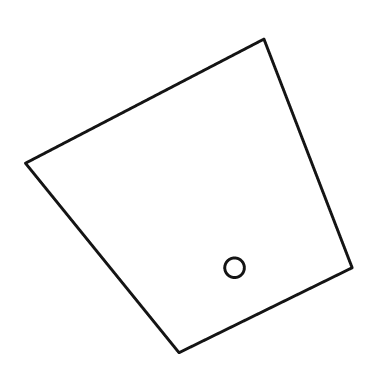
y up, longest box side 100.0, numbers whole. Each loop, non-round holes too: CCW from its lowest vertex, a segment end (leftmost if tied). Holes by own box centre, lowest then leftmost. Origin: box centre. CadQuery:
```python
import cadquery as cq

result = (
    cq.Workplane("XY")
    .moveTo(-3.0, -48.0)
    .lineTo(50.0, -22.0)
    .lineTo(23.0, 48.0)
    .lineTo(-50.0, 10.0)
    .close()
    .moveTo(14.0, -22.0)
    .circle(3.0)
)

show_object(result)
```